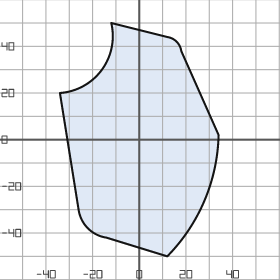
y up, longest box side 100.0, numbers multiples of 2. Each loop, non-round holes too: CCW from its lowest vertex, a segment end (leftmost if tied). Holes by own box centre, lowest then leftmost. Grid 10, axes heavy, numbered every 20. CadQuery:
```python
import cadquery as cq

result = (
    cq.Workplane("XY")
    .moveTo(12.0, -50.0)
    .threePointArc((28.0, -26.0), (34.0, 2.0))
    .lineTo(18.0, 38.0)
    .threePointArc((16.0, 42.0), (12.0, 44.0))
    .lineTo(-12.0, 50.0)
    .threePointArc((-16.0, 30.0), (-34.0, 20.0))
    .lineTo(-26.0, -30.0)
    .threePointArc((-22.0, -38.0), (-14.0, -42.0))
    .close()
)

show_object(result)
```